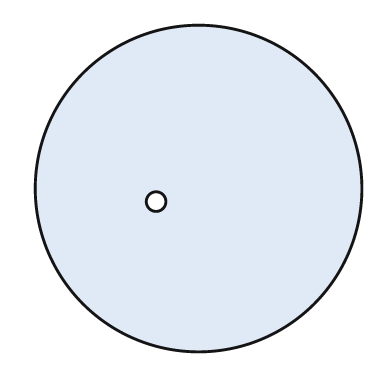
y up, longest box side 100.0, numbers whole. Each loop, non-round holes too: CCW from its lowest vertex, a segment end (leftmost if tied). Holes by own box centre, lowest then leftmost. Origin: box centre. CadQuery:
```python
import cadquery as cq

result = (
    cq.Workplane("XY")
    .moveTo(0.0, 0.0)
    .circle(50.0)
    .moveTo(-13.0, -4.0)
    .circle(3.0)
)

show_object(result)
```